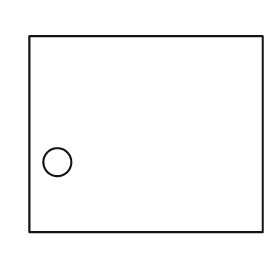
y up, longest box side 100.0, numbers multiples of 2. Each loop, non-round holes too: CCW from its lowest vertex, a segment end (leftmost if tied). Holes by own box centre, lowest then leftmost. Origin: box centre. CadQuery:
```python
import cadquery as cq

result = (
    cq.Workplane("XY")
    .moveTo(-50.0, -42.0)
    .lineTo(50.0, -42.0)
    .lineTo(50.0, 42.0)
    .lineTo(-50.0, 42.0)
    .close()
    .moveTo(-38.0, -12.0)
    .circle(6.0)
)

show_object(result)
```